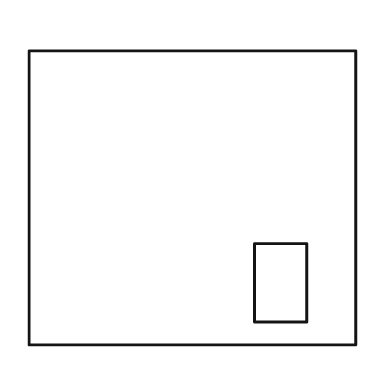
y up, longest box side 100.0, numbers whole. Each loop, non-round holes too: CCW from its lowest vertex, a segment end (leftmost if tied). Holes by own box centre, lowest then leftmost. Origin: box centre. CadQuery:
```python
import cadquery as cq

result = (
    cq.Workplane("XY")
    .moveTo(-50.0, -45.0)
    .lineTo(50.0, -45.0)
    .lineTo(50.0, 45.0)
    .lineTo(-50.0, 45.0)
    .close()
    .moveTo(19.0, -38.0)
    .lineTo(35.0, -38.0)
    .lineTo(35.0, -14.0)
    .lineTo(19.0, -14.0)
    .close()
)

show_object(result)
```